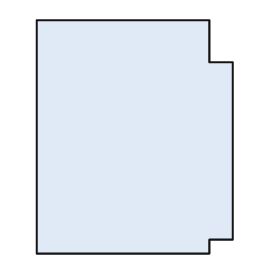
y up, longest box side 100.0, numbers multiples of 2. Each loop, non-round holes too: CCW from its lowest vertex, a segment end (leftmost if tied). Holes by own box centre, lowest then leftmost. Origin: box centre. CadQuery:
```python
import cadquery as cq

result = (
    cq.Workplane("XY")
    .moveTo(-42.0, -50.0)
    .lineTo(32.0, -50.0)
    .lineTo(32.0, -44.0)
    .lineTo(42.0, -44.0)
    .lineTo(42.0, 32.0)
    .lineTo(32.0, 32.0)
    .lineTo(32.0, 50.0)
    .lineTo(-42.0, 50.0)
    .close()
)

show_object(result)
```